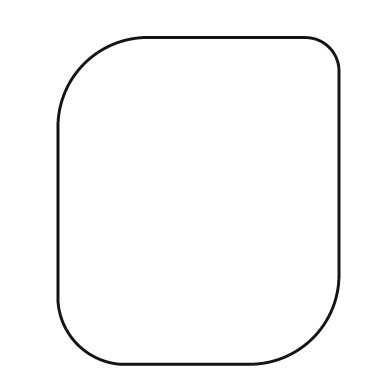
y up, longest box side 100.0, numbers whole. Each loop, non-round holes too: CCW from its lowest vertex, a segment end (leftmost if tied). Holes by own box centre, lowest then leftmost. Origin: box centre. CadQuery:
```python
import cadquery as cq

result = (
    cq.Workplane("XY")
    .moveTo(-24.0, -50.0)
    .lineTo(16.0, -50.0)
    .threePointArc((35.0, -42.0), (43.0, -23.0))
    .lineTo(43.0, 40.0)
    .threePointArc((40.0, 47.0), (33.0, 50.0))
    .lineTo(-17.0, 50.0)
    .threePointArc((-35.0, 42.0), (-43.0, 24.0))
    .lineTo(-43.0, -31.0)
    .threePointArc((-37.0, -44.0), (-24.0, -50.0))
    .close()
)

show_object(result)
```